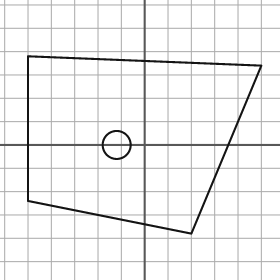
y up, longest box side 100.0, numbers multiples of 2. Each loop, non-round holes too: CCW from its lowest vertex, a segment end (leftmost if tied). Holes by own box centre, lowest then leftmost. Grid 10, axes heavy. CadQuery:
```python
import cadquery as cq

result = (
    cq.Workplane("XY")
    .moveTo(20.0, -38.0)
    .lineTo(50.0, 34.0)
    .lineTo(-50.0, 38.0)
    .lineTo(-50.0, -24.0)
    .close()
    .moveTo(-12.0, 0.0)
    .circle(6.0)
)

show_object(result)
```